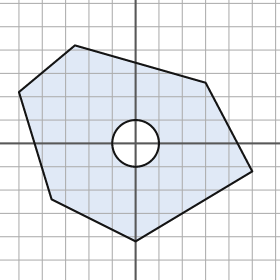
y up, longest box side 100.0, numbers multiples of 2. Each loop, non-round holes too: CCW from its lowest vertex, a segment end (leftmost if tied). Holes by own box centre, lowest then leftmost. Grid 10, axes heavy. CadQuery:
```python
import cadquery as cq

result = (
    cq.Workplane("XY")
    .moveTo(0.0, -42.0)
    .lineTo(50.0, -12.0)
    .lineTo(30.0, 26.0)
    .lineTo(-26.0, 42.0)
    .lineTo(-50.0, 22.0)
    .lineTo(-36.0, -24.0)
    .close()
    .moveTo(0.0, 0.0)
    .circle(10.0)
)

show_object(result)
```